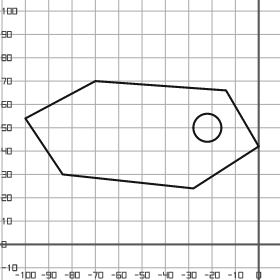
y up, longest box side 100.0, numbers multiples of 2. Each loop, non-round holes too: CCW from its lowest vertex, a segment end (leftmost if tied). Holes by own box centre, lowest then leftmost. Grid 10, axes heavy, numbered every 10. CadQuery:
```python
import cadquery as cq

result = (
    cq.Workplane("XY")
    .moveTo(-28.0, 24.0)
    .lineTo(0.0, 42.0)
    .lineTo(-14.0, 66.0)
    .lineTo(-70.0, 70.0)
    .lineTo(-100.0, 54.0)
    .lineTo(-84.0, 30.0)
    .close()
    .moveTo(-22.0, 50.0)
    .circle(6.0)
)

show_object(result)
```